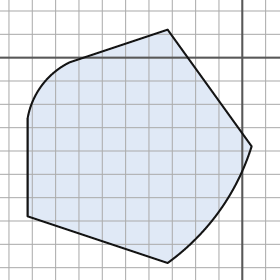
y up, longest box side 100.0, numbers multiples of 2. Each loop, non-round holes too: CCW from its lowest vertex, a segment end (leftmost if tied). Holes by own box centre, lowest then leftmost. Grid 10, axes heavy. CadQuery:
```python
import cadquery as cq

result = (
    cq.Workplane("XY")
    .moveTo(-32.0, -88.0)
    .threePointArc((-10.0, -66.0), (4.0, -38.0))
    .lineTo(-32.0, 12.0)
    .lineTo(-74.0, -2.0)
    .threePointArc((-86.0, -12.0), (-92.0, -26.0))
    .lineTo(-92.0, -68.0)
    .close()
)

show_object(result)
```